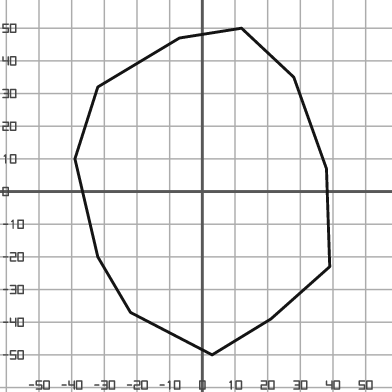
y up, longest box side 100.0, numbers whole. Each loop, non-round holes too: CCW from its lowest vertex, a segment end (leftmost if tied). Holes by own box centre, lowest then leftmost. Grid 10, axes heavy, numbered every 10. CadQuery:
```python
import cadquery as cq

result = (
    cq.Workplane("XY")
    .moveTo(3.0, -50.0)
    .lineTo(21.0, -39.0)
    .lineTo(39.0, -23.0)
    .lineTo(38.0, 7.0)
    .lineTo(28.0, 35.0)
    .lineTo(12.0, 50.0)
    .lineTo(-7.0, 47.0)
    .lineTo(-32.0, 32.0)
    .lineTo(-39.0, 10.0)
    .lineTo(-32.0, -20.0)
    .lineTo(-22.0, -37.0)
    .close()
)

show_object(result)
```